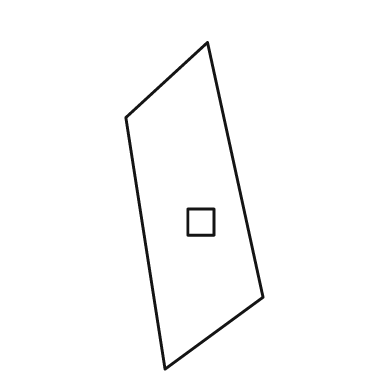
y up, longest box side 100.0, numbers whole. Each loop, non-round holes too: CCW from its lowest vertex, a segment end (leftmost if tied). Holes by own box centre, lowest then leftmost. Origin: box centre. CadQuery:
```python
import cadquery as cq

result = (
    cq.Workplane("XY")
    .moveTo(-9.0, -50.0)
    .lineTo(21.0, -28.0)
    .lineTo(4.0, 50.0)
    .lineTo(-21.0, 27.0)
    .close()
    .moveTo(-2.0, -9.0)
    .lineTo(6.0, -9.0)
    .lineTo(6.0, -1.0)
    .lineTo(-2.0, -1.0)
    .close()
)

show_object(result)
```